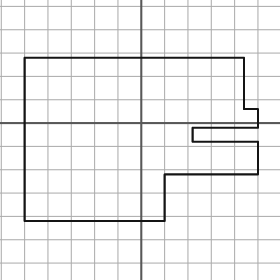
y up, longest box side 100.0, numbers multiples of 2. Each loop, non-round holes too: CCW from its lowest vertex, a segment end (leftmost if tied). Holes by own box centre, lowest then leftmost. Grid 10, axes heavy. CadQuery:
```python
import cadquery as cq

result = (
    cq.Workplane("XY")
    .moveTo(-50.0, -42.0)
    .lineTo(10.0, -42.0)
    .lineTo(10.0, -22.0)
    .lineTo(50.0, -22.0)
    .lineTo(50.0, -8.0)
    .lineTo(22.0, -8.0)
    .lineTo(22.0, -2.0)
    .lineTo(50.0, -2.0)
    .lineTo(50.0, 6.0)
    .lineTo(44.0, 6.0)
    .lineTo(44.0, 28.0)
    .lineTo(-50.0, 28.0)
    .close()
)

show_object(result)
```